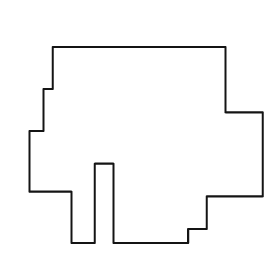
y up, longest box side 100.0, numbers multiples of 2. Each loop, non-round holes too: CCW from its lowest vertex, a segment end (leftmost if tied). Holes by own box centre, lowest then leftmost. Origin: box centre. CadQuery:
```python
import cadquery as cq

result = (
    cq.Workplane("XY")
    .moveTo(-32.0, -42.0)
    .lineTo(-22.0, -42.0)
    .lineTo(-22.0, -8.0)
    .lineTo(-14.0, -8.0)
    .lineTo(-14.0, -42.0)
    .lineTo(18.0, -42.0)
    .lineTo(18.0, -36.0)
    .lineTo(26.0, -36.0)
    .lineTo(26.0, -22.0)
    .lineTo(50.0, -22.0)
    .lineTo(50.0, 14.0)
    .lineTo(34.0, 14.0)
    .lineTo(34.0, 42.0)
    .lineTo(-40.0, 42.0)
    .lineTo(-40.0, 24.0)
    .lineTo(-44.0, 24.0)
    .lineTo(-44.0, 6.0)
    .lineTo(-50.0, 6.0)
    .lineTo(-50.0, -20.0)
    .lineTo(-32.0, -20.0)
    .close()
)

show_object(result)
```